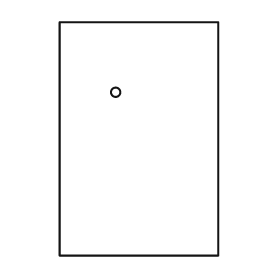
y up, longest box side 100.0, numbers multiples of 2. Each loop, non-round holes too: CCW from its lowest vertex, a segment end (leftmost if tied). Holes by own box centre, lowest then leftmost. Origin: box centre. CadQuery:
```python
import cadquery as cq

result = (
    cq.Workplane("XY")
    .moveTo(-34.0, -50.0)
    .lineTo(34.0, -50.0)
    .lineTo(34.0, 50.0)
    .lineTo(-34.0, 50.0)
    .close()
    .moveTo(-10.0, 20.0)
    .circle(2.0)
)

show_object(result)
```